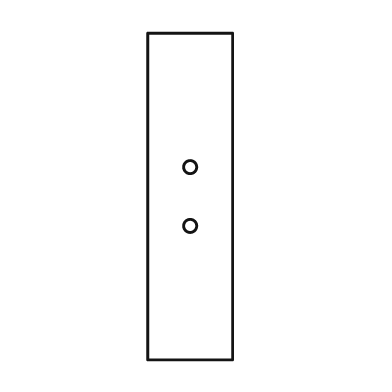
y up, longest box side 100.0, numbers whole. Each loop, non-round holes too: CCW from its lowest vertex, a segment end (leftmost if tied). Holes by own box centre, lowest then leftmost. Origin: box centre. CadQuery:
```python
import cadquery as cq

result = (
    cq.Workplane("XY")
    .moveTo(-13.0, -50.0)
    .lineTo(13.0, -50.0)
    .lineTo(13.0, 50.0)
    .lineTo(-13.0, 50.0)
    .close()
    .moveTo(0.0, -9.0)
    .circle(2.0)
    .moveTo(0.0, 9.0)
    .circle(2.0)
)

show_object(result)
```